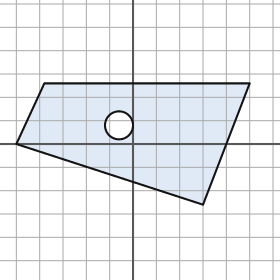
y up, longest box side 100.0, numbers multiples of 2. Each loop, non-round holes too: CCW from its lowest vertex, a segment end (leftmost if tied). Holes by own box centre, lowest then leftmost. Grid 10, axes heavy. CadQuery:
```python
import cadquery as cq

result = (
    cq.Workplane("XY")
    .moveTo(30.0, -26.0)
    .lineTo(50.0, 26.0)
    .lineTo(-38.0, 26.0)
    .lineTo(-50.0, 0.0)
    .close()
    .moveTo(-6.0, 8.0)
    .circle(6.0)
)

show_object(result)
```